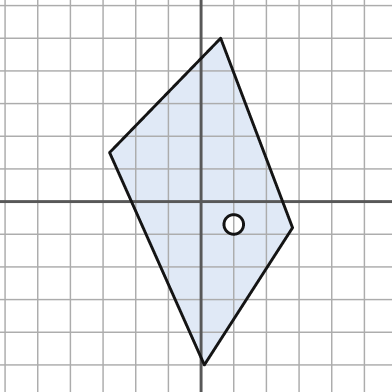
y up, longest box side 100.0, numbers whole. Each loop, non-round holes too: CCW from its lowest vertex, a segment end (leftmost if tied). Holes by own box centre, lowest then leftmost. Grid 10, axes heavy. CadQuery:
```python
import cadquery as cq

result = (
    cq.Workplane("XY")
    .moveTo(1.0, -50.0)
    .lineTo(28.0, -8.0)
    .lineTo(6.0, 50.0)
    .lineTo(-28.0, 15.0)
    .close()
    .moveTo(10.0, -7.0)
    .circle(3.0)
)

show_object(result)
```